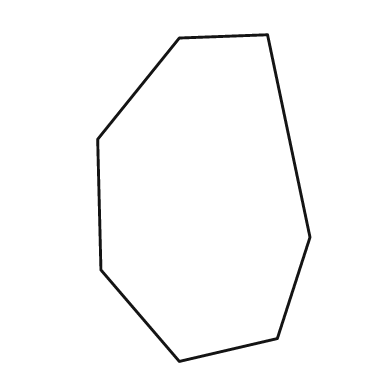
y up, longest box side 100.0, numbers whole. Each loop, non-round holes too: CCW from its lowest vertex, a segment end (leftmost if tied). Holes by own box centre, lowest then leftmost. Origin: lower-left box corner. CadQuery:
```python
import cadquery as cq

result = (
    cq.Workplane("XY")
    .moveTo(25.0, 0.0)
    .lineTo(55.0, 7.0)
    .lineTo(65.0, 38.0)
    .lineTo(52.0, 100.0)
    .lineTo(25.0, 99.0)
    .lineTo(0.0, 68.0)
    .lineTo(1.0, 28.0)
    .close()
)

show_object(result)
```